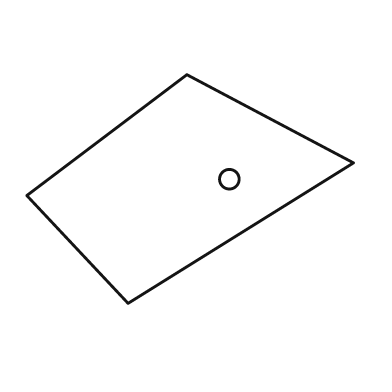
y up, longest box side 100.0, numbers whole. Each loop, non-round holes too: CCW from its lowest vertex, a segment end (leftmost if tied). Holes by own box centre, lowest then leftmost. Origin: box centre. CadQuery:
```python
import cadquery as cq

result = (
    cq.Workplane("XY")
    .moveTo(-19.0, -35.0)
    .lineTo(50.0, 8.0)
    .lineTo(-1.0, 35.0)
    .lineTo(-50.0, -2.0)
    .close()
    .moveTo(12.0, 3.0)
    .circle(3.0)
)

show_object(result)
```